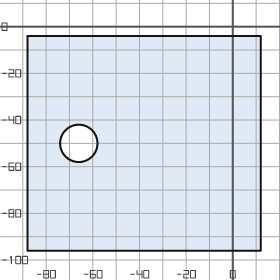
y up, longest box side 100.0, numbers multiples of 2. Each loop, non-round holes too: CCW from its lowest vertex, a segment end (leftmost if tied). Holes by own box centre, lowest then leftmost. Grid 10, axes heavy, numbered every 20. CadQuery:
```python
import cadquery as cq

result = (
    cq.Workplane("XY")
    .moveTo(-88.0, -96.0)
    .lineTo(12.0, -96.0)
    .lineTo(12.0, -4.0)
    .lineTo(-88.0, -4.0)
    .close()
    .moveTo(-66.0, -50.0)
    .circle(8.0)
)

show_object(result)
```